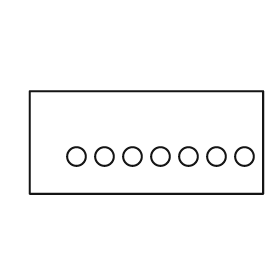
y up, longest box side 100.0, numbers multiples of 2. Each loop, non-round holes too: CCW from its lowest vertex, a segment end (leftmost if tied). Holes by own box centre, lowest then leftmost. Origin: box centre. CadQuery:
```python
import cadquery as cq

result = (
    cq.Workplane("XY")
    .moveTo(-50.0, -22.0)
    .lineTo(50.0, -22.0)
    .lineTo(50.0, 22.0)
    .lineTo(-50.0, 22.0)
    .close()
    .moveTo(-30.0, -6.0)
    .circle(4.0)
    .moveTo(-18.0, -6.0)
    .circle(4.0)
    .moveTo(-6.0, -6.0)
    .circle(4.0)
    .moveTo(6.0, -6.0)
    .circle(4.0)
    .moveTo(18.0, -6.0)
    .circle(4.0)
    .moveTo(30.0, -6.0)
    .circle(4.0)
    .moveTo(42.0, -6.0)
    .circle(4.0)
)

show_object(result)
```